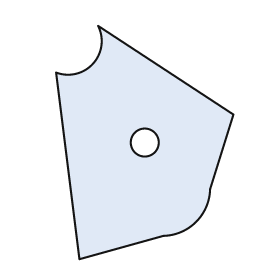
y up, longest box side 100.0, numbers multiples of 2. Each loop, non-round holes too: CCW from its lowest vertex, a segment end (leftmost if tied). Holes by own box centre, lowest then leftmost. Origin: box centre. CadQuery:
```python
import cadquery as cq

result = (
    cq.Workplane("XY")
    .moveTo(-28.0, -50.0)
    .lineTo(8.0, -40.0)
    .threePointArc((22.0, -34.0), (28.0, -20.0))
    .lineTo(38.0, 12.0)
    .lineTo(-20.0, 50.0)
    .threePointArc((-22.0, 34.0), (-38.0, 30.0))
    .close()
    .moveTo(0.0, 0.0)
    .circle(6.0)
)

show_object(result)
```